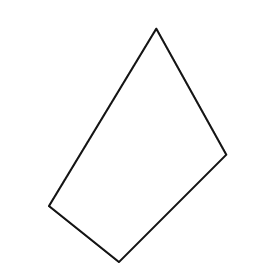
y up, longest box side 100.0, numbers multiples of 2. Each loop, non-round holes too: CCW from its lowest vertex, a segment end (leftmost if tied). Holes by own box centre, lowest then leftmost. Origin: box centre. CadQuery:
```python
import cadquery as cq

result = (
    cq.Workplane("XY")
    .moveTo(-8.0, -50.0)
    .lineTo(38.0, -4.0)
    .lineTo(8.0, 50.0)
    .lineTo(-38.0, -26.0)
    .close()
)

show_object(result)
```